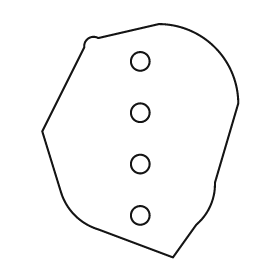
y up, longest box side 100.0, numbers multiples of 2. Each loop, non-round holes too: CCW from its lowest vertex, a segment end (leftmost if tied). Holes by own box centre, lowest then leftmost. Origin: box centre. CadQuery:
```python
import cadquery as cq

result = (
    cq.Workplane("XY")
    .moveTo(14.0, -50.0)
    .lineTo(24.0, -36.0)
    .threePointArc((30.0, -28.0), (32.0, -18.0))
    .lineTo(42.0, 16.0)
    .threePointArc((32.0, 40.0), (8.0, 50.0))
    .lineTo(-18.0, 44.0)
    .threePointArc((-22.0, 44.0), (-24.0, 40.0))
    .lineTo(-42.0, 4.0)
    .lineTo(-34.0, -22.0)
    .threePointArc((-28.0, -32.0), (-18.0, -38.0))
    .close()
    .moveTo(0.0, -32.0)
    .circle(4.0)
    .moveTo(0.0, -10.0)
    .circle(4.0)
    .moveTo(0.0, 12.0)
    .circle(4.0)
    .moveTo(0.0, 34.0)
    .circle(4.0)
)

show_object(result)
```